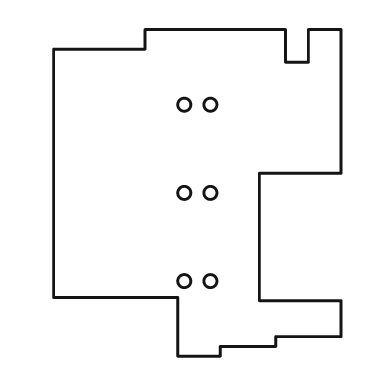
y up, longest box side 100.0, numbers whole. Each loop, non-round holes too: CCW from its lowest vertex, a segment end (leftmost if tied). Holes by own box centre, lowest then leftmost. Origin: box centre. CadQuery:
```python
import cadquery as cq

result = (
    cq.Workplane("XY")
    .moveTo(-6.0, -50.0)
    .lineTo(7.0, -50.0)
    .lineTo(7.0, -47.0)
    .lineTo(24.0, -47.0)
    .lineTo(24.0, -44.0)
    .lineTo(44.0, -44.0)
    .lineTo(44.0, -33.0)
    .lineTo(19.0, -33.0)
    .lineTo(19.0, 6.0)
    .lineTo(44.0, 6.0)
    .lineTo(44.0, 50.0)
    .lineTo(34.0, 50.0)
    .lineTo(34.0, 40.0)
    .lineTo(27.0, 40.0)
    .lineTo(27.0, 50.0)
    .lineTo(-16.0, 50.0)
    .lineTo(-16.0, 44.0)
    .lineTo(-44.0, 44.0)
    .lineTo(-44.0, -32.0)
    .lineTo(-6.0, -32.0)
    .close()
    .moveTo(-4.0, -27.0)
    .circle(2.0)
    .moveTo(4.0, -27.0)
    .circle(2.0)
    .moveTo(-4.0, 0.0)
    .circle(2.0)
    .moveTo(4.0, 0.0)
    .circle(2.0)
    .moveTo(-4.0, 27.0)
    .circle(2.0)
    .moveTo(4.0, 27.0)
    .circle(2.0)
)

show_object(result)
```